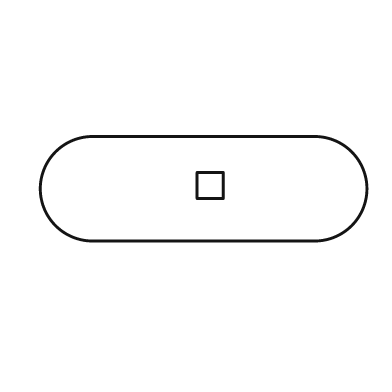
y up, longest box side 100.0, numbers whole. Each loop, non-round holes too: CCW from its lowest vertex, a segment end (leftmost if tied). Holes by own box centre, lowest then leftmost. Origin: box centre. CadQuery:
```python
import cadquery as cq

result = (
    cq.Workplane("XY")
    .moveTo(-34.0, -16.0)
    .lineTo(34.0, -16.0)
    .threePointArc((50.0, 0.0), (34.0, 16.0))
    .lineTo(-34.0, 16.0)
    .threePointArc((-50.0, 0.0), (-34.0, -16.0))
    .close()
    .moveTo(-2.0, -3.0)
    .lineTo(6.0, -3.0)
    .lineTo(6.0, 5.0)
    .lineTo(-2.0, 5.0)
    .close()
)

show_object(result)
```